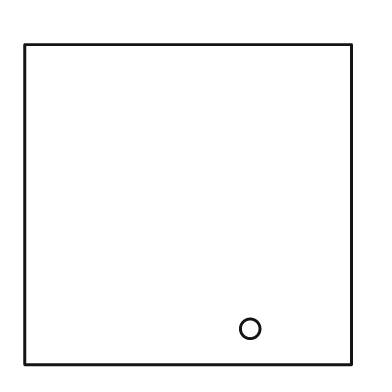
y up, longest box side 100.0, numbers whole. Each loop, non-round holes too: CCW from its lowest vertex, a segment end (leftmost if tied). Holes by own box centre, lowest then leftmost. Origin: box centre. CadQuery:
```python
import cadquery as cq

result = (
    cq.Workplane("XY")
    .moveTo(-50.0, -49.0)
    .lineTo(50.0, -49.0)
    .lineTo(50.0, 49.0)
    .lineTo(-50.0, 49.0)
    .close()
    .moveTo(19.0, -38.0)
    .circle(3.0)
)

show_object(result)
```